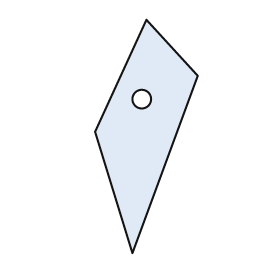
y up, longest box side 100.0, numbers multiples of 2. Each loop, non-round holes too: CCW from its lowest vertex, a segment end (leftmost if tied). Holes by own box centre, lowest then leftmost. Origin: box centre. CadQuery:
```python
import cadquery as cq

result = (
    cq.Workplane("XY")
    .moveTo(-6.0, -50.0)
    .lineTo(22.0, 26.0)
    .lineTo(0.0, 50.0)
    .lineTo(-22.0, 2.0)
    .close()
    .moveTo(-2.0, 16.0)
    .circle(4.0)
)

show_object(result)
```